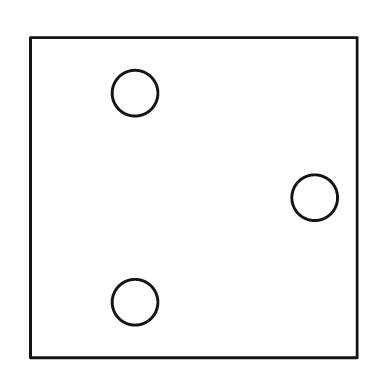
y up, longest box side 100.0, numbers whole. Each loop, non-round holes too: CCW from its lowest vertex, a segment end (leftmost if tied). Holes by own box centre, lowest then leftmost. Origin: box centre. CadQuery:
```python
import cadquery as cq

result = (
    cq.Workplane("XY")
    .moveTo(-50.0, -49.0)
    .lineTo(50.0, -49.0)
    .lineTo(50.0, 49.0)
    .lineTo(-50.0, 49.0)
    .close()
    .moveTo(-18.0, -32.0)
    .circle(7.0)
    .moveTo(37.0, 0.0)
    .circle(7.0)
    .moveTo(-18.0, 32.0)
    .circle(7.0)
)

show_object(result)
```